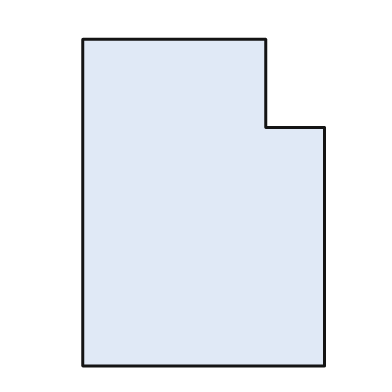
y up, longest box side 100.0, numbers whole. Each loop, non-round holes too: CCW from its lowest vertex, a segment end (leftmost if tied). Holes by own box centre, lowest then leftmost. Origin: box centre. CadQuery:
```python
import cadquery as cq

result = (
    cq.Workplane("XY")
    .moveTo(-37.0, -50.0)
    .lineTo(37.0, -50.0)
    .lineTo(37.0, 23.0)
    .lineTo(19.0, 23.0)
    .lineTo(19.0, 50.0)
    .lineTo(-37.0, 50.0)
    .close()
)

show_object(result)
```